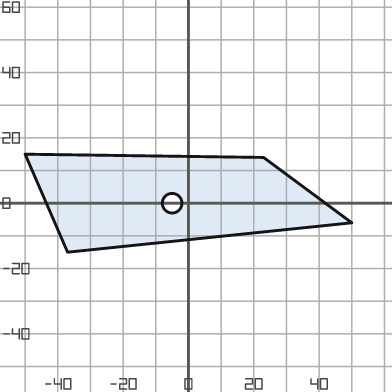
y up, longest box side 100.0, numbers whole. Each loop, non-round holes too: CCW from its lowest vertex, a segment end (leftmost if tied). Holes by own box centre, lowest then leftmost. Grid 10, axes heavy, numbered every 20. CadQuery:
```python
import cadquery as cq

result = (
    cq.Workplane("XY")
    .moveTo(-37.0, -15.0)
    .lineTo(50.0, -6.0)
    .lineTo(23.0, 14.0)
    .lineTo(-50.0, 15.0)
    .close()
    .moveTo(-5.0, 0.0)
    .circle(3.0)
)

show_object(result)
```